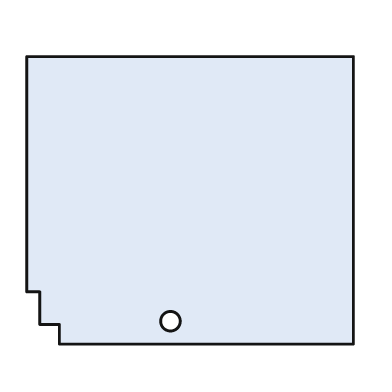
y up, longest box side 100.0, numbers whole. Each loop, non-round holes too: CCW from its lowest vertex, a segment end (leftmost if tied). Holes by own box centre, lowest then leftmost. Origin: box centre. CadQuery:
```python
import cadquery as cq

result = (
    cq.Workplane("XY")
    .moveTo(-40.0, -44.0)
    .lineTo(50.0, -44.0)
    .lineTo(50.0, 44.0)
    .lineTo(-50.0, 44.0)
    .lineTo(-50.0, -28.0)
    .lineTo(-46.0, -28.0)
    .lineTo(-46.0, -38.0)
    .lineTo(-40.0, -38.0)
    .close()
    .moveTo(-6.0, -37.0)
    .circle(3.0)
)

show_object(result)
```